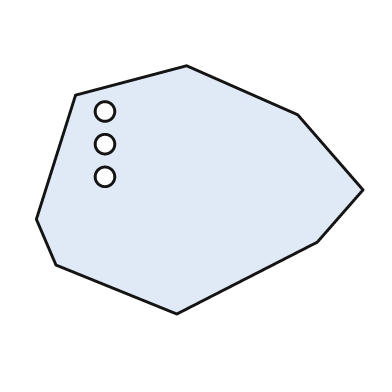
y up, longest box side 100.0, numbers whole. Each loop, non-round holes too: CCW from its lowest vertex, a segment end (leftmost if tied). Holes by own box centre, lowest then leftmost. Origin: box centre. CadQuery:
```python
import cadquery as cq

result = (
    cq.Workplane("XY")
    .moveTo(-7.0, -38.0)
    .lineTo(36.0, -16.0)
    .lineTo(50.0, 0.0)
    .lineTo(30.0, 23.0)
    .lineTo(-4.0, 38.0)
    .lineTo(-38.0, 29.0)
    .lineTo(-50.0, -9.0)
    .lineTo(-44.0, -23.0)
    .close()
    .moveTo(-29.0, 4.0)
    .circle(3.0)
    .moveTo(-29.0, 14.0)
    .circle(3.0)
    .moveTo(-29.0, 24.0)
    .circle(3.0)
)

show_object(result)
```